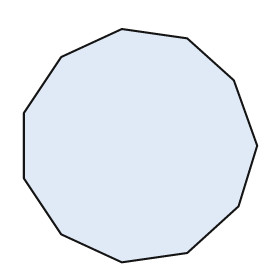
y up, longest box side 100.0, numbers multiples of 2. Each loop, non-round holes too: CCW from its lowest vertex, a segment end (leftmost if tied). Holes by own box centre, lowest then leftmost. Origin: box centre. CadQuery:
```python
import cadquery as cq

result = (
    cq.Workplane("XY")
    .moveTo(-8.0, -50.0)
    .lineTo(20.0, -46.0)
    .lineTo(42.0, -26.0)
    .lineTo(50.0, 0.0)
    .lineTo(40.0, 28.0)
    .lineTo(20.0, 46.0)
    .lineTo(-8.0, 50.0)
    .lineTo(-34.0, 38.0)
    .lineTo(-50.0, 14.0)
    .lineTo(-50.0, -14.0)
    .lineTo(-34.0, -38.0)
    .close()
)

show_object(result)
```